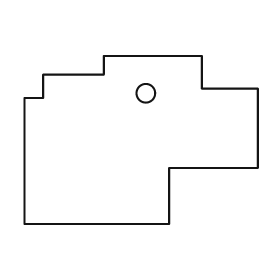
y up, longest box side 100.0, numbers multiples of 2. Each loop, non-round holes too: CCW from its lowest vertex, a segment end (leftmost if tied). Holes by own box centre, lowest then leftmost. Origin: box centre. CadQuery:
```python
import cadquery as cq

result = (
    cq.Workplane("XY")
    .moveTo(-50.0, -36.0)
    .lineTo(12.0, -36.0)
    .lineTo(12.0, -12.0)
    .lineTo(50.0, -12.0)
    .lineTo(50.0, 22.0)
    .lineTo(26.0, 22.0)
    .lineTo(26.0, 36.0)
    .lineTo(-16.0, 36.0)
    .lineTo(-16.0, 28.0)
    .lineTo(-42.0, 28.0)
    .lineTo(-42.0, 18.0)
    .lineTo(-50.0, 18.0)
    .close()
    .moveTo(2.0, 20.0)
    .circle(4.0)
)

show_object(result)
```